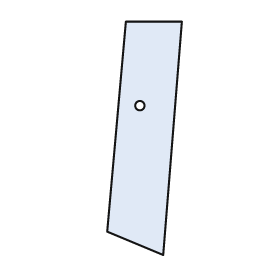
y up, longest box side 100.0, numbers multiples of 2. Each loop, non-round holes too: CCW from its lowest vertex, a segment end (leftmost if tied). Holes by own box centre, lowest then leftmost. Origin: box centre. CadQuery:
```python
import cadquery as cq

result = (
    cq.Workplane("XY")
    .moveTo(8.0, -50.0)
    .lineTo(16.0, 50.0)
    .lineTo(-8.0, 50.0)
    .lineTo(-16.0, -40.0)
    .close()
    .moveTo(-2.0, 14.0)
    .circle(2.0)
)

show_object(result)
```